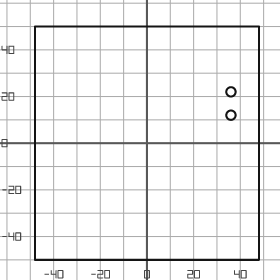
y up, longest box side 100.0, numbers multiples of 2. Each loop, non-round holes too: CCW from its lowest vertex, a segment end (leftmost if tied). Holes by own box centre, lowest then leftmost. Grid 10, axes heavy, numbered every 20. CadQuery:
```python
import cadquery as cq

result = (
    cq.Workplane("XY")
    .moveTo(-48.0, -50.0)
    .lineTo(48.0, -50.0)
    .lineTo(48.0, 50.0)
    .lineTo(-48.0, 50.0)
    .close()
    .moveTo(36.0, 12.0)
    .circle(2.0)
    .moveTo(36.0, 22.0)
    .circle(2.0)
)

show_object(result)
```